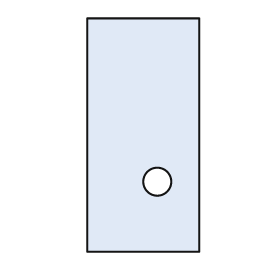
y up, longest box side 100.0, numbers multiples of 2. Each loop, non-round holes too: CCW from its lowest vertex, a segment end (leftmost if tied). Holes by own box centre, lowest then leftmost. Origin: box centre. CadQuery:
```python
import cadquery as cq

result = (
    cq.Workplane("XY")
    .moveTo(-24.0, -50.0)
    .lineTo(24.0, -50.0)
    .lineTo(24.0, 50.0)
    .lineTo(-24.0, 50.0)
    .close()
    .moveTo(6.0, -20.0)
    .circle(6.0)
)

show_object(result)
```